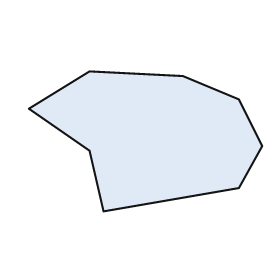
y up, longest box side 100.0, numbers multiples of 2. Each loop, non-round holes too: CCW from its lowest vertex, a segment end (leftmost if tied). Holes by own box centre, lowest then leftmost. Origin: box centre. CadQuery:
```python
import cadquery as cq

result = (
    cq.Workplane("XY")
    .moveTo(-18.0, -30.0)
    .lineTo(40.0, -20.0)
    .lineTo(50.0, -2.0)
    .lineTo(40.0, 18.0)
    .lineTo(16.0, 28.0)
    .lineTo(-24.0, 30.0)
    .lineTo(-50.0, 14.0)
    .lineTo(-24.0, -4.0)
    .close()
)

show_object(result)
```